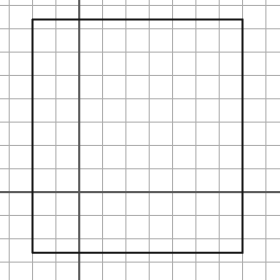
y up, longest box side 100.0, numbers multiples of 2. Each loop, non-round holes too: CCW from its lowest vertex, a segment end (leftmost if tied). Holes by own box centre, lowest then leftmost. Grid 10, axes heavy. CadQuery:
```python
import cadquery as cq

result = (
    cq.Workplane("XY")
    .moveTo(-20.0, -26.0)
    .lineTo(70.0, -26.0)
    .lineTo(70.0, 74.0)
    .lineTo(-20.0, 74.0)
    .close()
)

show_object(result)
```